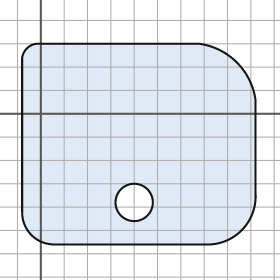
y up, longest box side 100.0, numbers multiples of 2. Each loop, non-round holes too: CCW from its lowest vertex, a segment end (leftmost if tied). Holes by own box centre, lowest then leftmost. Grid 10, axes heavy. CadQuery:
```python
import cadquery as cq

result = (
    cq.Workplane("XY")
    .moveTo(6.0, -56.0)
    .lineTo(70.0, -56.0)
    .threePointArc((86.0, -50.0), (92.0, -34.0))
    .lineTo(92.0, 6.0)
    .threePointArc((84.0, 22.0), (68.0, 30.0))
    .lineTo(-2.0, 30.0)
    .threePointArc((-6.0, 28.0), (-8.0, 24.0))
    .lineTo(-8.0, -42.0)
    .threePointArc((-4.0, -52.0), (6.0, -56.0))
    .close()
    .moveTo(40.0, -38.0)
    .circle(8.0)
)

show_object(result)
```